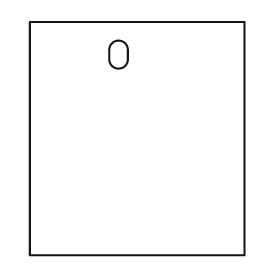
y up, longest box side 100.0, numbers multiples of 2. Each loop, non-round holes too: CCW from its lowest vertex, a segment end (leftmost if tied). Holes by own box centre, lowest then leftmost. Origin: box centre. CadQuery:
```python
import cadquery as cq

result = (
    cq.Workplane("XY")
    .moveTo(-46.0, -50.0)
    .lineTo(46.0, -50.0)
    .lineTo(46.0, 50.0)
    .lineTo(-46.0, 50.0)
    .close()
    .moveTo(-12.0, 34.0)
    .threePointArc((-8.0, 30.0), (-4.0, 34.0))
    .lineTo(-4.0, 38.0)
    .threePointArc((-8.0, 42.0), (-12.0, 38.0))
    .close()
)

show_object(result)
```